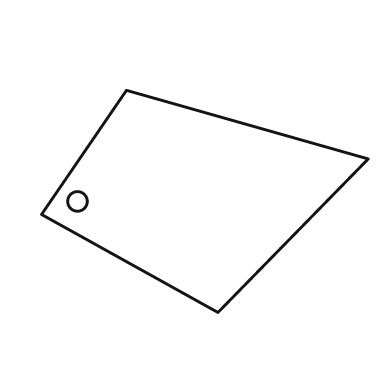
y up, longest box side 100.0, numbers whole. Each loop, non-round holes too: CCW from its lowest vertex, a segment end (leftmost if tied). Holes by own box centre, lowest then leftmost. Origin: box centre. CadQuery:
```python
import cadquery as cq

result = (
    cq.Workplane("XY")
    .moveTo(4.0, -34.0)
    .lineTo(50.0, 13.0)
    .lineTo(-24.0, 34.0)
    .lineTo(-50.0, -4.0)
    .close()
    .moveTo(-39.0, 0.0)
    .circle(3.0)
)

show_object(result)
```